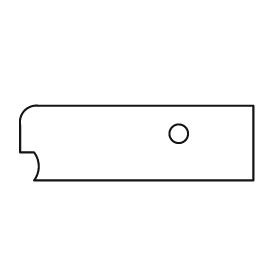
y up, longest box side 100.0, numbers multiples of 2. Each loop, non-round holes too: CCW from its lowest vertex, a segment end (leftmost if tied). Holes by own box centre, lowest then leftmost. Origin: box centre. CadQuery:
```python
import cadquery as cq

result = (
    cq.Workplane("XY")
    .moveTo(-44.0, -16.0)
    .lineTo(50.0, -16.0)
    .lineTo(50.0, 16.0)
    .lineTo(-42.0, 16.0)
    .threePointArc((-48.0, 14.0), (-50.0, 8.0))
    .lineTo(-50.0, -4.0)
    .lineTo(-44.0, -4.0)
    .threePointArc((-42.0, -10.0), (-44.0, -16.0))
    .close()
    .moveTo(18.0, 4.0)
    .circle(4.0)
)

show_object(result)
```